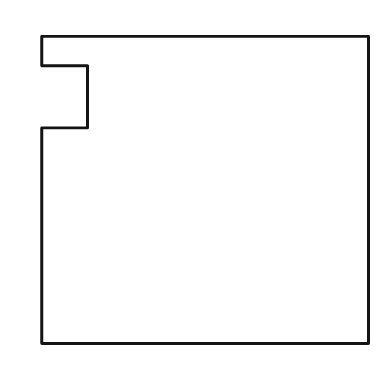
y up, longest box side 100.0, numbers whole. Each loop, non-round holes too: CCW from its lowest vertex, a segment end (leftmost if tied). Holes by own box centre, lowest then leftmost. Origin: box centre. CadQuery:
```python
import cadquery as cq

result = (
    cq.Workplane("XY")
    .moveTo(-50.0, -47.0)
    .lineTo(50.0, -47.0)
    .lineTo(50.0, 47.0)
    .lineTo(-50.0, 47.0)
    .lineTo(-50.0, 38.0)
    .lineTo(-36.0, 38.0)
    .lineTo(-36.0, 19.0)
    .lineTo(-50.0, 19.0)
    .close()
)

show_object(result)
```